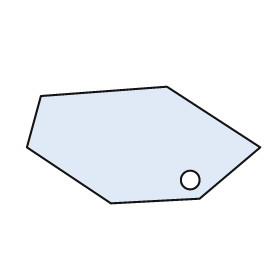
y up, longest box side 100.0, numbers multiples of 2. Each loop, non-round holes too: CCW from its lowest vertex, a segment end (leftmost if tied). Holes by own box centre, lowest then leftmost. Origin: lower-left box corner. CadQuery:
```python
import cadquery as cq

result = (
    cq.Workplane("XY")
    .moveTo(36.0, 0.0)
    .lineTo(74.0, 2.0)
    .lineTo(100.0, 24.0)
    .lineTo(60.0, 50.0)
    .lineTo(6.0, 46.0)
    .lineTo(0.0, 24.0)
    .close()
    .moveTo(70.0, 10.0)
    .circle(4.0)
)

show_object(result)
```